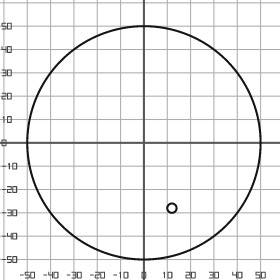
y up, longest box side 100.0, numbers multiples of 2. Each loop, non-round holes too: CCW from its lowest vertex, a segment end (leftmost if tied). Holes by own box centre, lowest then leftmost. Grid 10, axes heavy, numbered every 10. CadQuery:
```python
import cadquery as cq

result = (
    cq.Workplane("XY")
    .moveTo(0.0, 0.0)
    .circle(50.0)
    .moveTo(12.0, -28.0)
    .circle(2.0)
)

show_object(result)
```